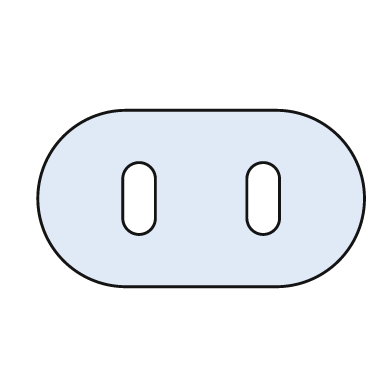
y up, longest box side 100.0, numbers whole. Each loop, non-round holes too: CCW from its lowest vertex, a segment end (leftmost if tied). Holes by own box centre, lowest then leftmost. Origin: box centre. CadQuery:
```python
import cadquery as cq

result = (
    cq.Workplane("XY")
    .moveTo(-23.0, -27.0)
    .lineTo(23.0, -27.0)
    .threePointArc((50.0, 0.0), (23.0, 27.0))
    .lineTo(-23.0, 27.0)
    .threePointArc((-50.0, 0.0), (-23.0, -27.0))
    .close()
    .moveTo(-24.0, -6.0)
    .threePointArc((-19.0, -11.0), (-14.0, -6.0))
    .lineTo(-14.0, 6.0)
    .threePointArc((-19.0, 11.0), (-24.0, 6.0))
    .close()
    .moveTo(14.0, -6.0)
    .threePointArc((19.0, -11.0), (24.0, -6.0))
    .lineTo(24.0, 6.0)
    .threePointArc((19.0, 11.0), (14.0, 6.0))
    .close()
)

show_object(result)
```